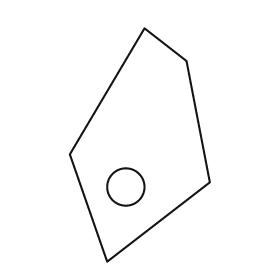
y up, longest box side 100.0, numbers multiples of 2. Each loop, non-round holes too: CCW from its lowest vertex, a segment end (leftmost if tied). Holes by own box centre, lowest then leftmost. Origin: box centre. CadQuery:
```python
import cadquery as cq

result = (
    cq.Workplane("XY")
    .moveTo(-14.0, -50.0)
    .lineTo(30.0, -16.0)
    .lineTo(20.0, 36.0)
    .lineTo(2.0, 50.0)
    .lineTo(-30.0, -4.0)
    .close()
    .moveTo(-6.0, -18.0)
    .circle(8.0)
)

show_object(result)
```